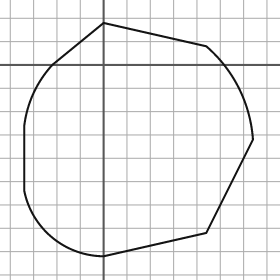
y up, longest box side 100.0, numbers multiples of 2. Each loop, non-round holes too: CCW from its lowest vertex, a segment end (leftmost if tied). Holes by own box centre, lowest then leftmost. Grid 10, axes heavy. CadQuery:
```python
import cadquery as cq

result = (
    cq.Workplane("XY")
    .moveTo(0.0, -82.0)
    .lineTo(44.0, -72.0)
    .lineTo(64.0, -32.0)
    .threePointArc((58.0, -10.0), (44.0, 8.0))
    .lineTo(0.0, 18.0)
    .lineTo(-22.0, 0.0)
    .threePointArc((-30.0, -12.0), (-34.0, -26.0))
    .lineTo(-34.0, -54.0)
    .threePointArc((-22.0, -74.0), (0.0, -82.0))
    .close()
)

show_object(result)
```